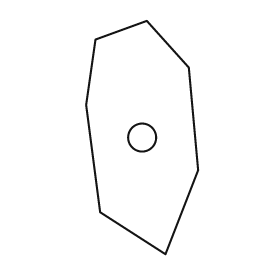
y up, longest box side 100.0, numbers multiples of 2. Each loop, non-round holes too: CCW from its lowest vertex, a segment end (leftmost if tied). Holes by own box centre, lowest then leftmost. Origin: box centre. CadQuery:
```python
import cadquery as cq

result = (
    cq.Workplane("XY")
    .moveTo(10.0, -50.0)
    .lineTo(24.0, -14.0)
    .lineTo(20.0, 30.0)
    .lineTo(2.0, 50.0)
    .lineTo(-20.0, 42.0)
    .lineTo(-24.0, 14.0)
    .lineTo(-18.0, -32.0)
    .close()
    .moveTo(0.0, 0.0)
    .circle(6.0)
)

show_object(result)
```